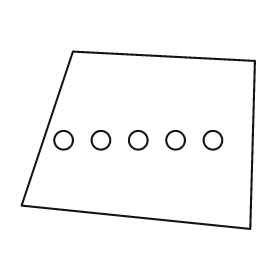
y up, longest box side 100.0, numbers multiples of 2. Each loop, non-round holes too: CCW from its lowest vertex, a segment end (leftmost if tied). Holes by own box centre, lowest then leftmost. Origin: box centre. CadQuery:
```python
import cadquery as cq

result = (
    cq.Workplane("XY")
    .moveTo(48.0, -38.0)
    .lineTo(50.0, 34.0)
    .lineTo(-28.0, 38.0)
    .lineTo(-50.0, -28.0)
    .close()
    .moveTo(-32.0, 0.0)
    .circle(4.0)
    .moveTo(-16.0, 0.0)
    .circle(4.0)
    .moveTo(0.0, 0.0)
    .circle(4.0)
    .moveTo(16.0, 0.0)
    .circle(4.0)
    .moveTo(32.0, 0.0)
    .circle(4.0)
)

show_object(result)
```